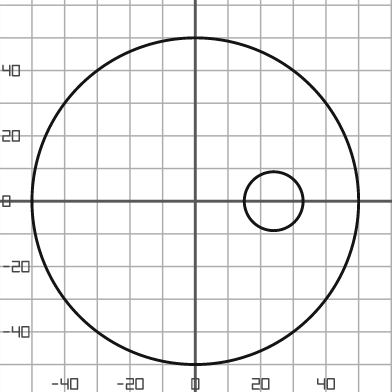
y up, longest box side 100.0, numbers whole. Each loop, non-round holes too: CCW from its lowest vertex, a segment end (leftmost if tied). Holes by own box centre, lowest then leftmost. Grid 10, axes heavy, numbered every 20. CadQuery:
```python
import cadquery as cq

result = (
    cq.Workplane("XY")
    .moveTo(0.0, 0.0)
    .circle(50.0)
    .moveTo(24.0, 0.0)
    .circle(9.0)
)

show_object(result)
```